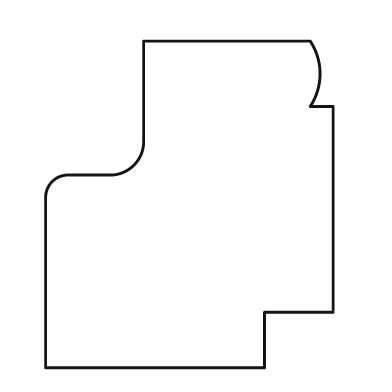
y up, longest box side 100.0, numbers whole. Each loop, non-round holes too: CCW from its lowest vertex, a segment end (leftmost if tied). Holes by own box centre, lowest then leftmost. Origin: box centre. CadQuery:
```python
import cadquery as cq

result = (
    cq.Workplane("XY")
    .moveTo(-44.0, -50.0)
    .lineTo(23.0, -50.0)
    .lineTo(23.0, -33.0)
    .lineTo(44.0, -33.0)
    .lineTo(44.0, 30.0)
    .lineTo(37.0, 30.0)
    .threePointArc((40.0, 40.0), (37.0, 50.0))
    .lineTo(-14.0, 50.0)
    .lineTo(-14.0, 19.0)
    .threePointArc((-17.0, 12.0), (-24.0, 9.0))
    .lineTo(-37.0, 9.0)
    .threePointArc((-42.0, 7.0), (-44.0, 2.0))
    .close()
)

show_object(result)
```